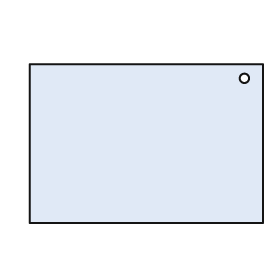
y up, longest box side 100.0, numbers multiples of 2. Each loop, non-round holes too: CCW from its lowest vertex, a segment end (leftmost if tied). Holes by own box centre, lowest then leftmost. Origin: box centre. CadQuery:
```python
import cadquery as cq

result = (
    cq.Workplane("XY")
    .moveTo(-50.0, -34.0)
    .lineTo(50.0, -34.0)
    .lineTo(50.0, 34.0)
    .lineTo(-50.0, 34.0)
    .close()
    .moveTo(42.0, 28.0)
    .circle(2.0)
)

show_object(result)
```